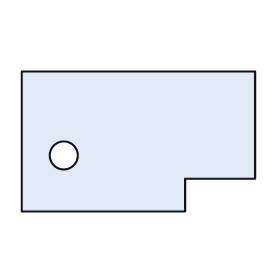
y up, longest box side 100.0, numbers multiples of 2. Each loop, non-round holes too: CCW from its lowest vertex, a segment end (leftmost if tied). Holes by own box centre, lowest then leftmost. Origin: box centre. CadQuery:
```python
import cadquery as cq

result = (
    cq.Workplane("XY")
    .moveTo(-50.0, -30.0)
    .lineTo(20.0, -30.0)
    .lineTo(20.0, -16.0)
    .lineTo(50.0, -16.0)
    .lineTo(50.0, 30.0)
    .lineTo(-50.0, 30.0)
    .close()
    .moveTo(-32.0, -6.0)
    .circle(6.0)
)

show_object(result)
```